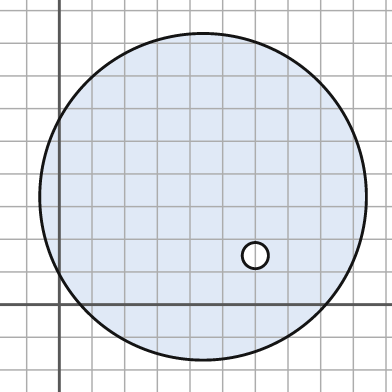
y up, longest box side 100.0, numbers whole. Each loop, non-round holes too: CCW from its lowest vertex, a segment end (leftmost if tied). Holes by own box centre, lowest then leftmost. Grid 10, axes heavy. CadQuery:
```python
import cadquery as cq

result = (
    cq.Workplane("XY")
    .moveTo(44.0, 33.0)
    .circle(50.0)
    .moveTo(60.0, 15.0)
    .circle(4.0)
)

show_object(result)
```